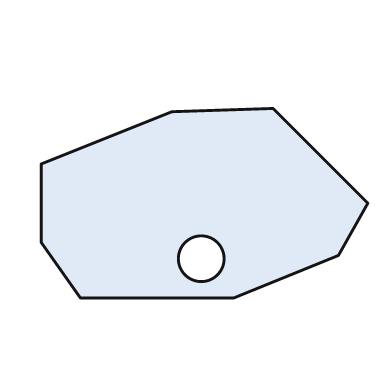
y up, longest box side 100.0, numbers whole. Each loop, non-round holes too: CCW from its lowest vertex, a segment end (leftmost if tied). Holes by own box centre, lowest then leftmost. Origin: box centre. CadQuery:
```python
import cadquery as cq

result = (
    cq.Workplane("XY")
    .moveTo(-38.0, -29.0)
    .lineTo(9.0, -29.0)
    .lineTo(41.0, -16.0)
    .lineTo(50.0, 0.0)
    .lineTo(21.0, 29.0)
    .lineTo(-10.0, 28.0)
    .lineTo(-50.0, 12.0)
    .lineTo(-50.0, -12.0)
    .close()
    .moveTo(-1.0, -17.0)
    .circle(7.0)
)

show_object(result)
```